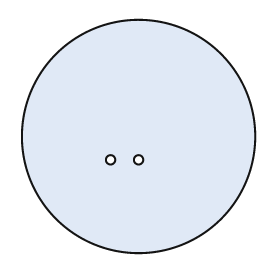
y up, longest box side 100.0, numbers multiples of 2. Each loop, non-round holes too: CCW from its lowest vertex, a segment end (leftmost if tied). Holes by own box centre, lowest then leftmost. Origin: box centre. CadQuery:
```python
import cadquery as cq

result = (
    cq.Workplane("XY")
    .moveTo(0.0, 0.0)
    .circle(50.0)
    .moveTo(-12.0, -10.0)
    .circle(2.0)
    .moveTo(0.0, -10.0)
    .circle(2.0)
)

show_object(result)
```